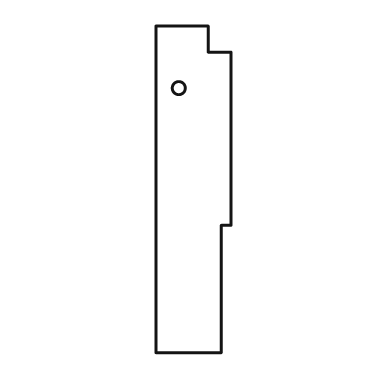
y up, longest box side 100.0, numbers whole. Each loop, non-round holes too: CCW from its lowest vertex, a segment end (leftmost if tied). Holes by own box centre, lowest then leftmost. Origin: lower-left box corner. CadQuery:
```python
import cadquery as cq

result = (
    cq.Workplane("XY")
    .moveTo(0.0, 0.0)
    .lineTo(20.0, 0.0)
    .lineTo(20.0, 39.0)
    .lineTo(23.0, 39.0)
    .lineTo(23.0, 92.0)
    .lineTo(16.0, 92.0)
    .lineTo(16.0, 100.0)
    .lineTo(0.0, 100.0)
    .close()
    .moveTo(7.0, 81.0)
    .circle(2.0)
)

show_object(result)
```